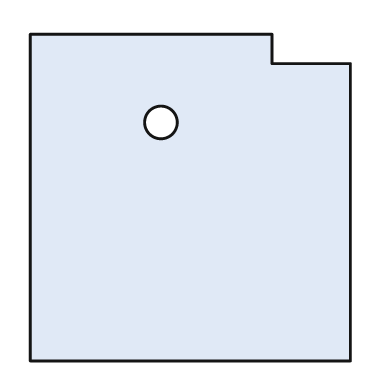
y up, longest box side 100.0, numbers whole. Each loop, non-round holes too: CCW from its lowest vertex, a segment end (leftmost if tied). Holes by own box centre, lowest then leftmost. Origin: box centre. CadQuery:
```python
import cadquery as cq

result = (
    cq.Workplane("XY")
    .moveTo(-49.0, -50.0)
    .lineTo(49.0, -50.0)
    .lineTo(49.0, 41.0)
    .lineTo(25.0, 41.0)
    .lineTo(25.0, 50.0)
    .lineTo(-49.0, 50.0)
    .close()
    .moveTo(-9.0, 23.0)
    .circle(5.0)
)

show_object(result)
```